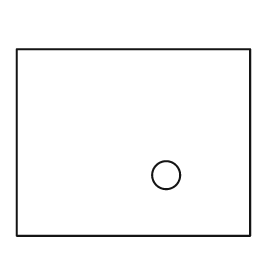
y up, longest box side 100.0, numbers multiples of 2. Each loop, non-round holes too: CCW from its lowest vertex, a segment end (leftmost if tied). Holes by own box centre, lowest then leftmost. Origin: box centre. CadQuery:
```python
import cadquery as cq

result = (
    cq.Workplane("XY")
    .moveTo(-50.0, -40.0)
    .lineTo(50.0, -40.0)
    .lineTo(50.0, 40.0)
    .lineTo(-50.0, 40.0)
    .close()
    .moveTo(14.0, -14.0)
    .circle(6.0)
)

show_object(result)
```